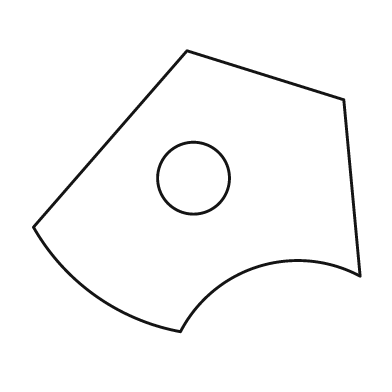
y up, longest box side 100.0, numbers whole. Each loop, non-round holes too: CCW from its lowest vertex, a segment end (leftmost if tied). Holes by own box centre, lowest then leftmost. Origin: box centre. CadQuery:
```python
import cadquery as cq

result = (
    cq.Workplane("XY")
    .moveTo(-5.0, -43.0)
    .threePointArc((19.0, -23.0), (50.0, -26.0))
    .lineTo(45.0, 28.0)
    .lineTo(-3.0, 43.0)
    .lineTo(-50.0, -11.0)
    .threePointArc((-31.0, -32.0), (-5.0, -43.0))
    .close()
    .moveTo(-1.0, 4.0)
    .circle(11.0)
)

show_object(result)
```